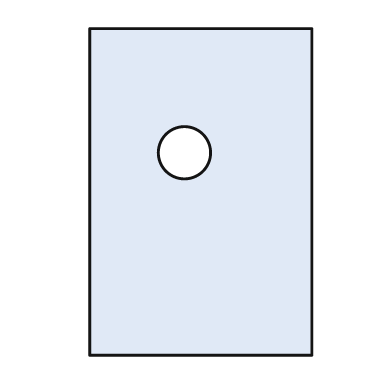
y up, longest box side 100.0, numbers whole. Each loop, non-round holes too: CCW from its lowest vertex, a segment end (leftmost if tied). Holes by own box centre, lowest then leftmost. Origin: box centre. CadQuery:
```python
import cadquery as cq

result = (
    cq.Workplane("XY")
    .moveTo(-34.0, -50.0)
    .lineTo(34.0, -50.0)
    .lineTo(34.0, 50.0)
    .lineTo(-34.0, 50.0)
    .close()
    .moveTo(-5.0, 12.0)
    .circle(8.0)
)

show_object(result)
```